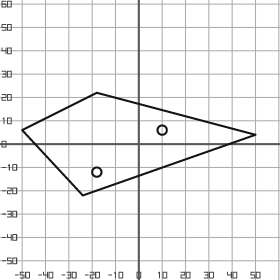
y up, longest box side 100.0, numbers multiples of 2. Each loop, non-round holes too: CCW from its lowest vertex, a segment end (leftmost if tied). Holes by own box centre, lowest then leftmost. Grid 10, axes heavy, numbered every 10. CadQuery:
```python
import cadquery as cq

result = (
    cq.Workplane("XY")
    .moveTo(-24.0, -22.0)
    .lineTo(50.0, 4.0)
    .lineTo(-18.0, 22.0)
    .lineTo(-50.0, 6.0)
    .close()
    .moveTo(-18.0, -12.0)
    .circle(2.0)
    .moveTo(10.0, 6.0)
    .circle(2.0)
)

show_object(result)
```